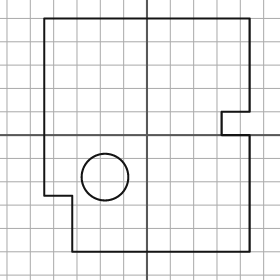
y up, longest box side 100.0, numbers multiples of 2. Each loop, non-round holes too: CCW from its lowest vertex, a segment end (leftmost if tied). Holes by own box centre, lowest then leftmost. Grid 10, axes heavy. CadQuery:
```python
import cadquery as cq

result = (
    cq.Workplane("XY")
    .moveTo(-32.0, -50.0)
    .lineTo(44.0, -50.0)
    .lineTo(44.0, 0.0)
    .lineTo(32.0, 0.0)
    .lineTo(32.0, 10.0)
    .lineTo(44.0, 10.0)
    .lineTo(44.0, 50.0)
    .lineTo(-44.0, 50.0)
    .lineTo(-44.0, -26.0)
    .lineTo(-32.0, -26.0)
    .close()
    .moveTo(-18.0, -18.0)
    .circle(10.0)
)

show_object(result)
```